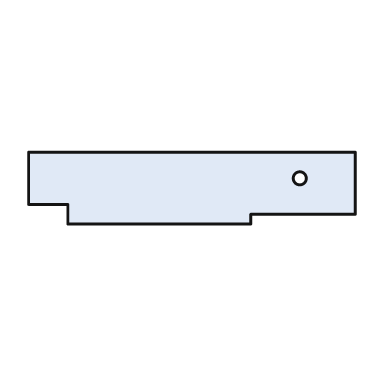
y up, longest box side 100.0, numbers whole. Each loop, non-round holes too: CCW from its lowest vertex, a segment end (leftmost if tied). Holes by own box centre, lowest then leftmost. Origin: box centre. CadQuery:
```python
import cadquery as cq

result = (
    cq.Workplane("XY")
    .moveTo(-38.0, -11.0)
    .lineTo(18.0, -11.0)
    .lineTo(18.0, -8.0)
    .lineTo(50.0, -8.0)
    .lineTo(50.0, 11.0)
    .lineTo(-50.0, 11.0)
    .lineTo(-50.0, -5.0)
    .lineTo(-38.0, -5.0)
    .close()
    .moveTo(33.0, 3.0)
    .circle(2.0)
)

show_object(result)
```